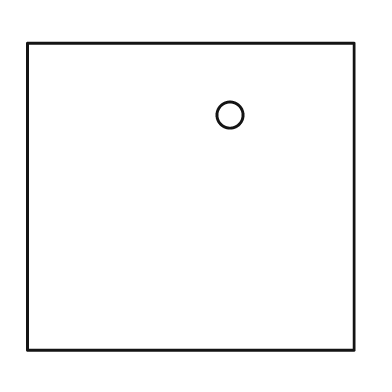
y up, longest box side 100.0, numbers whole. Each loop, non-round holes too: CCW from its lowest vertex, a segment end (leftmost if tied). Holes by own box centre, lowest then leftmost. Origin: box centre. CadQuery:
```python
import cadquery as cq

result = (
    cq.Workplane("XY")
    .moveTo(-50.0, -47.0)
    .lineTo(50.0, -47.0)
    .lineTo(50.0, 47.0)
    .lineTo(-50.0, 47.0)
    .close()
    .moveTo(12.0, 25.0)
    .circle(4.0)
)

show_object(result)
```